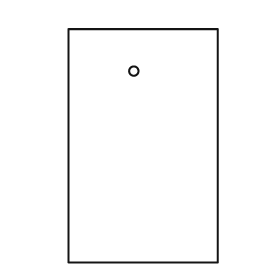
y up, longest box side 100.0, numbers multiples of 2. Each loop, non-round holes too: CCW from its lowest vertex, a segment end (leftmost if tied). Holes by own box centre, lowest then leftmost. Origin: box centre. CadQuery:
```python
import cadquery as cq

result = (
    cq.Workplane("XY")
    .moveTo(-32.0, -50.0)
    .lineTo(32.0, -50.0)
    .lineTo(32.0, 50.0)
    .lineTo(-32.0, 50.0)
    .close()
    .moveTo(-4.0, 32.0)
    .circle(2.0)
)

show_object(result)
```